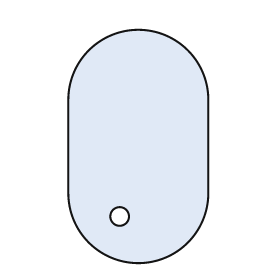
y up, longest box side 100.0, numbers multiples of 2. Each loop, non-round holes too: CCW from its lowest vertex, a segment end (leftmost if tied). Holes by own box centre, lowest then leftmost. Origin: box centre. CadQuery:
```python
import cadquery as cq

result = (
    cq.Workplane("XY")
    .moveTo(-30.0, -20.0)
    .threePointArc((0.0, -50.0), (30.0, -20.0))
    .lineTo(30.0, 20.0)
    .threePointArc((0.0, 50.0), (-30.0, 20.0))
    .close()
    .moveTo(-8.0, -30.0)
    .circle(4.0)
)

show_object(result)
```